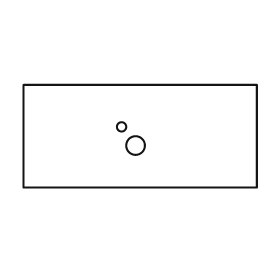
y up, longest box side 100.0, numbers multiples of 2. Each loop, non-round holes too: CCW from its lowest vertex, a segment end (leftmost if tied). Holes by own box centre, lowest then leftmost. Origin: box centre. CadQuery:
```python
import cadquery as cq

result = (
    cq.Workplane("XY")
    .moveTo(-50.0, -22.0)
    .lineTo(50.0, -22.0)
    .lineTo(50.0, 22.0)
    .lineTo(-50.0, 22.0)
    .close()
    .moveTo(-2.0, -4.0)
    .circle(4.0)
    .moveTo(-8.0, 4.0)
    .circle(2.0)
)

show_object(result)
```